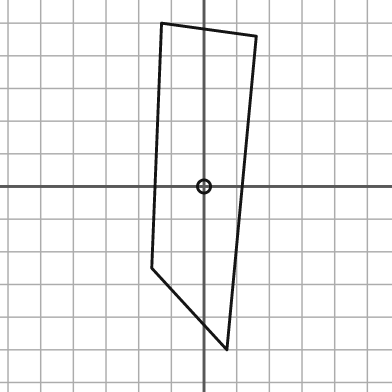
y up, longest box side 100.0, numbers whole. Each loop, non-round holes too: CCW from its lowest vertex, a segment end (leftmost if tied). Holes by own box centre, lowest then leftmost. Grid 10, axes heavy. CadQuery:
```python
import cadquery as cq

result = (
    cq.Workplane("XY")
    .moveTo(7.0, -50.0)
    .lineTo(16.0, 46.0)
    .lineTo(-13.0, 50.0)
    .lineTo(-16.0, -25.0)
    .close()
    .moveTo(0.0, 0.0)
    .circle(2.0)
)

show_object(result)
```